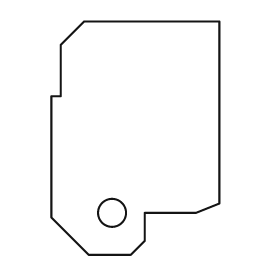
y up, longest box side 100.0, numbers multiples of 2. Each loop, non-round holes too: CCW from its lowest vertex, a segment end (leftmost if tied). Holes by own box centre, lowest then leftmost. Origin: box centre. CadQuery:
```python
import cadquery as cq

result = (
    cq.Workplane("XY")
    .moveTo(-20.0, -50.0)
    .lineTo(-2.0, -50.0)
    .lineTo(4.0, -44.0)
    .lineTo(4.0, -32.0)
    .lineTo(26.0, -32.0)
    .lineTo(36.0, -28.0)
    .lineTo(36.0, 50.0)
    .lineTo(-22.0, 50.0)
    .lineTo(-32.0, 40.0)
    .lineTo(-32.0, 18.0)
    .lineTo(-36.0, 18.0)
    .lineTo(-36.0, -34.0)
    .close()
    .moveTo(-10.0, -32.0)
    .circle(6.0)
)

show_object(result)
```